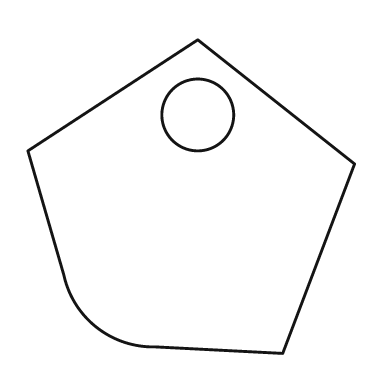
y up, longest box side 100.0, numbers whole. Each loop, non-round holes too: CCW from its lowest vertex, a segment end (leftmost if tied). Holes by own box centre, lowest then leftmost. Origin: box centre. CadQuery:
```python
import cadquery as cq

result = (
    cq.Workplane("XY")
    .moveTo(28.0, -48.0)
    .lineTo(50.0, 10.0)
    .lineTo(2.0, 48.0)
    .lineTo(-50.0, 14.0)
    .lineTo(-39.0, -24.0)
    .threePointArc((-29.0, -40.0), (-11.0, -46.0))
    .close()
    .moveTo(2.0, 25.0)
    .circle(11.0)
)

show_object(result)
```